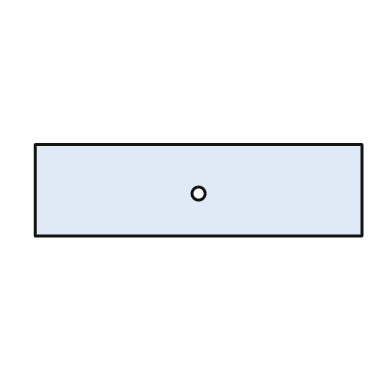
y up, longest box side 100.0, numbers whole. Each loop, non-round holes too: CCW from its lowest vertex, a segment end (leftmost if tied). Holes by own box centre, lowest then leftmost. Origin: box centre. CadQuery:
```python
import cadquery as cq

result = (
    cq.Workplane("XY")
    .moveTo(-50.0, -14.0)
    .lineTo(50.0, -14.0)
    .lineTo(50.0, 14.0)
    .lineTo(-50.0, 14.0)
    .close()
    .moveTo(0.0, -1.0)
    .circle(2.0)
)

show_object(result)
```